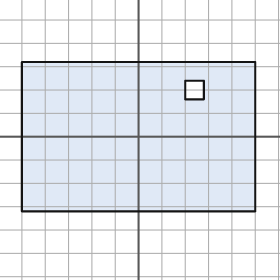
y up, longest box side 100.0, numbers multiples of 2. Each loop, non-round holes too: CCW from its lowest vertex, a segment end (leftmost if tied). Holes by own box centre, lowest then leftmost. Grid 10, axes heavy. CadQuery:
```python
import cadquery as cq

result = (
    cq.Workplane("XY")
    .moveTo(-50.0, -32.0)
    .lineTo(50.0, -32.0)
    .lineTo(50.0, 32.0)
    .lineTo(-50.0, 32.0)
    .close()
    .moveTo(20.0, 16.0)
    .lineTo(28.0, 16.0)
    .lineTo(28.0, 24.0)
    .lineTo(20.0, 24.0)
    .close()
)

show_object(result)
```